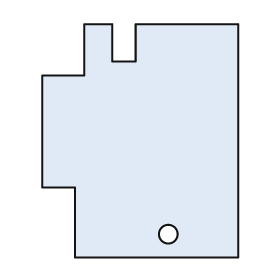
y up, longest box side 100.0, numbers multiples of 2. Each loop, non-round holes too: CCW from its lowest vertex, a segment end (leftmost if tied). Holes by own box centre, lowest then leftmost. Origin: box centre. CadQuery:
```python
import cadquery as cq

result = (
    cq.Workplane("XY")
    .moveTo(-28.0, -50.0)
    .lineTo(42.0, -50.0)
    .lineTo(42.0, 50.0)
    .lineTo(-2.0, 50.0)
    .lineTo(-2.0, 34.0)
    .lineTo(-12.0, 34.0)
    .lineTo(-12.0, 50.0)
    .lineTo(-24.0, 50.0)
    .lineTo(-24.0, 28.0)
    .lineTo(-42.0, 28.0)
    .lineTo(-42.0, -20.0)
    .lineTo(-28.0, -20.0)
    .close()
    .moveTo(12.0, -40.0)
    .circle(4.0)
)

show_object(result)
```